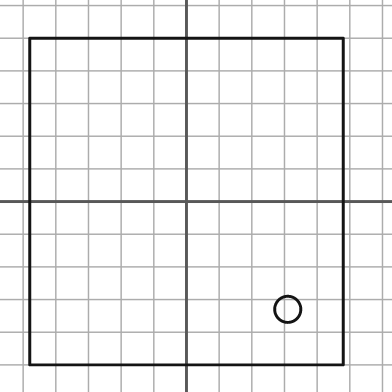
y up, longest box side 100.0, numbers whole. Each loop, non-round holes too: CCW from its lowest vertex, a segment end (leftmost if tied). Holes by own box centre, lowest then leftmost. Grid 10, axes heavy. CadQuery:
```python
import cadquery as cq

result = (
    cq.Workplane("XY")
    .moveTo(-48.0, -50.0)
    .lineTo(48.0, -50.0)
    .lineTo(48.0, 50.0)
    .lineTo(-48.0, 50.0)
    .close()
    .moveTo(31.0, -33.0)
    .circle(4.0)
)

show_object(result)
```